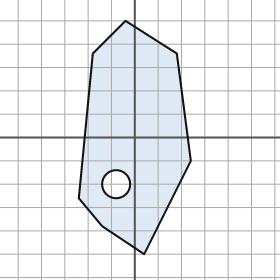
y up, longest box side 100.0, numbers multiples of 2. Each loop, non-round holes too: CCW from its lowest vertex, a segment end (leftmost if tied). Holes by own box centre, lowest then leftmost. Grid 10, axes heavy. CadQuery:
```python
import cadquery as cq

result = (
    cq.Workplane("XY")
    .moveTo(4.0, -50.0)
    .lineTo(24.0, -10.0)
    .lineTo(18.0, 36.0)
    .lineTo(-4.0, 50.0)
    .lineTo(-18.0, 36.0)
    .lineTo(-24.0, -26.0)
    .lineTo(-14.0, -38.0)
    .close()
    .moveTo(-8.0, -20.0)
    .circle(6.0)
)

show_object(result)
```